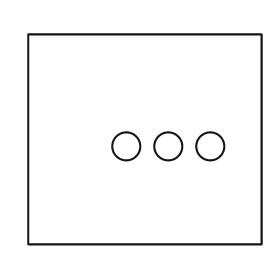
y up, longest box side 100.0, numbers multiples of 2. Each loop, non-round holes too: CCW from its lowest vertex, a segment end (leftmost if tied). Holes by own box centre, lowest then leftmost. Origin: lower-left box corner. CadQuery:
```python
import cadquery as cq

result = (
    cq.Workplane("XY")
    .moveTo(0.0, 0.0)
    .lineTo(100.0, 0.0)
    .lineTo(100.0, 90.0)
    .lineTo(0.0, 90.0)
    .close()
    .moveTo(42.0, 42.0)
    .circle(6.0)
    .moveTo(60.0, 42.0)
    .circle(6.0)
    .moveTo(78.0, 42.0)
    .circle(6.0)
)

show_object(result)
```